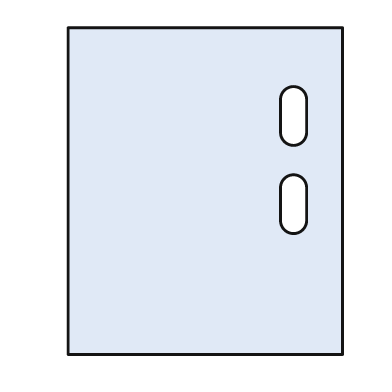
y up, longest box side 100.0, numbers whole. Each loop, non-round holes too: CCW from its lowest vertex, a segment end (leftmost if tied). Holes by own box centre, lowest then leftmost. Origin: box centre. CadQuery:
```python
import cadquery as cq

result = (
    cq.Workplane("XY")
    .moveTo(-42.0, -50.0)
    .lineTo(42.0, -50.0)
    .lineTo(42.0, 50.0)
    .lineTo(-42.0, 50.0)
    .close()
    .moveTo(23.0, -9.0)
    .threePointArc((27.0, -13.0), (31.0, -9.0))
    .lineTo(31.0, 1.0)
    .threePointArc((27.0, 5.0), (23.0, 1.0))
    .close()
    .moveTo(23.0, 18.0)
    .threePointArc((27.0, 14.0), (31.0, 18.0))
    .lineTo(31.0, 28.0)
    .threePointArc((27.0, 32.0), (23.0, 28.0))
    .close()
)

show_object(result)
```